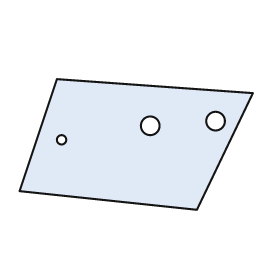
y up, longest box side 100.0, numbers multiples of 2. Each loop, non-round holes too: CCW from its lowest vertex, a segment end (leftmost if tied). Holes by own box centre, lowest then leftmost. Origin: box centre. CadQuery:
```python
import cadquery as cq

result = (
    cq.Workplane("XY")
    .moveTo(26.0, -28.0)
    .lineTo(50.0, 22.0)
    .lineTo(-34.0, 28.0)
    .lineTo(-50.0, -20.0)
    .close()
    .moveTo(-32.0, 2.0)
    .circle(2.0)
    .moveTo(6.0, 8.0)
    .circle(4.0)
    .moveTo(34.0, 10.0)
    .circle(4.0)
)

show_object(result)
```